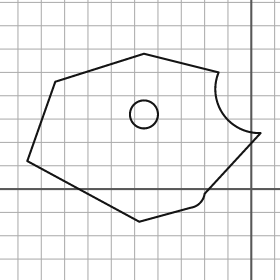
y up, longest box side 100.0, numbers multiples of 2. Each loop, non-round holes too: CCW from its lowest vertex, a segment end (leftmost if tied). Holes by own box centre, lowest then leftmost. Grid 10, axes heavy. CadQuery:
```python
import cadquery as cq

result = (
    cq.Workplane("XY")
    .moveTo(-48.0, -14.0)
    .lineTo(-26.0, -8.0)
    .threePointArc((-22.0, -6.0), (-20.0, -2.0))
    .lineTo(4.0, 24.0)
    .threePointArc((-12.0, 32.0), (-14.0, 50.0))
    .lineTo(-46.0, 58.0)
    .lineTo(-84.0, 46.0)
    .lineTo(-96.0, 12.0)
    .close()
    .moveTo(-46.0, 32.0)
    .circle(6.0)
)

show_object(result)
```